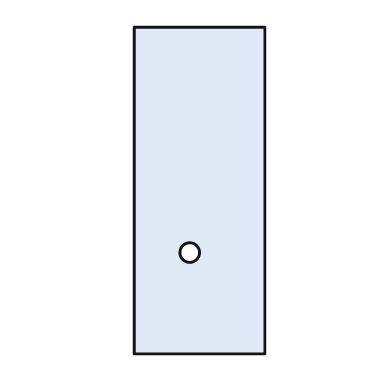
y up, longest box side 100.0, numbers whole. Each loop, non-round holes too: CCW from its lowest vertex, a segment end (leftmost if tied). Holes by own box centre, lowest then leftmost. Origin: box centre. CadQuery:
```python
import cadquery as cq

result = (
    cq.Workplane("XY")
    .moveTo(-20.0, -50.0)
    .lineTo(20.0, -50.0)
    .lineTo(20.0, 50.0)
    .lineTo(-20.0, 50.0)
    .close()
    .moveTo(-3.0, -19.0)
    .circle(3.0)
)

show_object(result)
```